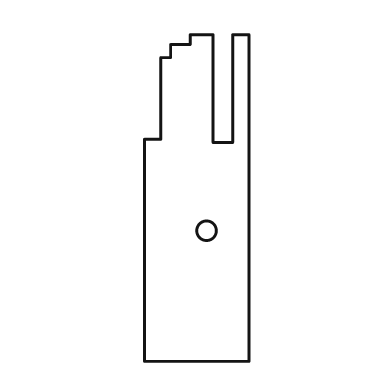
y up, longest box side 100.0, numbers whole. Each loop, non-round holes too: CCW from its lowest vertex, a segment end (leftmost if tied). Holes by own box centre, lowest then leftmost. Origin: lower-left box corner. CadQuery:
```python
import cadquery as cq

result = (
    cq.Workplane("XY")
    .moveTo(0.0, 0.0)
    .lineTo(32.0, 0.0)
    .lineTo(32.0, 100.0)
    .lineTo(27.0, 100.0)
    .lineTo(27.0, 67.0)
    .lineTo(21.0, 67.0)
    .lineTo(21.0, 100.0)
    .lineTo(14.0, 100.0)
    .lineTo(14.0, 97.0)
    .lineTo(8.0, 97.0)
    .lineTo(8.0, 93.0)
    .lineTo(5.0, 93.0)
    .lineTo(5.0, 68.0)
    .lineTo(0.0, 68.0)
    .close()
    .moveTo(19.0, 40.0)
    .circle(3.0)
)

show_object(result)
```